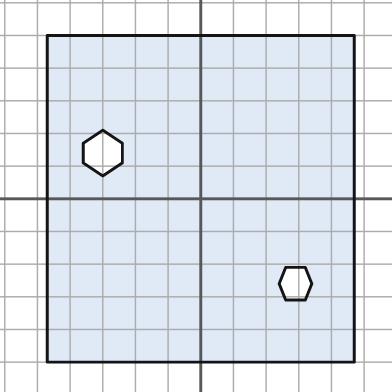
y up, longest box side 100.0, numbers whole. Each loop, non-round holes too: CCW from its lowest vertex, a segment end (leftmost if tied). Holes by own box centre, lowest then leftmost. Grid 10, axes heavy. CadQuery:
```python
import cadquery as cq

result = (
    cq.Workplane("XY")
    .moveTo(-47.0, -50.0)
    .lineTo(47.0, -50.0)
    .lineTo(47.0, 50.0)
    .lineTo(-47.0, 50.0)
    .close()
    .moveTo(26.0, -31.0)
    .lineTo(32.0, -31.0)
    .lineTo(34.0, -26.0)
    .lineTo(32.0, -21.0)
    .lineTo(26.0, -21.0)
    .lineTo(24.0, -26.0)
    .close()
    .moveTo(-30.0, 7.0)
    .lineTo(-24.0, 11.0)
    .lineTo(-24.0, 17.0)
    .lineTo(-30.0, 21.0)
    .lineTo(-36.0, 17.0)
    .lineTo(-36.0, 11.0)
    .close()
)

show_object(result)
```